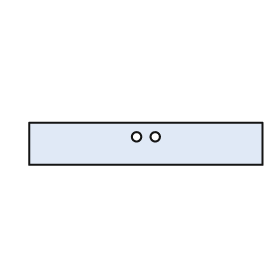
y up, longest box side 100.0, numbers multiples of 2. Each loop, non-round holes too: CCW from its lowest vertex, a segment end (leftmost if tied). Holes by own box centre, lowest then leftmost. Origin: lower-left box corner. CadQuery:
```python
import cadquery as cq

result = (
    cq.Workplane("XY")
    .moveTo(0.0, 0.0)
    .lineTo(100.0, 0.0)
    .lineTo(100.0, 18.0)
    .lineTo(0.0, 18.0)
    .close()
    .moveTo(46.0, 12.0)
    .circle(2.0)
    .moveTo(54.0, 12.0)
    .circle(2.0)
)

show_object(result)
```